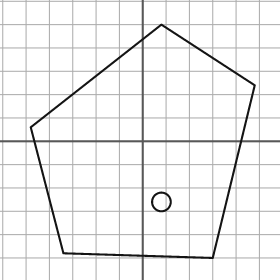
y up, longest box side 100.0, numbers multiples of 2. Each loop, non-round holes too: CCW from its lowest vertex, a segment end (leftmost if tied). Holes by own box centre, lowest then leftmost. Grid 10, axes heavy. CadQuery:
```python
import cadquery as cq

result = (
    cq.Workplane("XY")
    .moveTo(30.0, -50.0)
    .lineTo(48.0, 24.0)
    .lineTo(8.0, 50.0)
    .lineTo(-48.0, 6.0)
    .lineTo(-34.0, -48.0)
    .close()
    .moveTo(8.0, -26.0)
    .circle(4.0)
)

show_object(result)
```